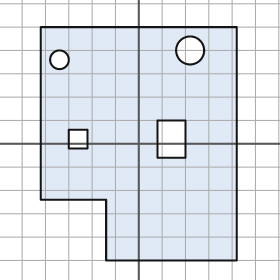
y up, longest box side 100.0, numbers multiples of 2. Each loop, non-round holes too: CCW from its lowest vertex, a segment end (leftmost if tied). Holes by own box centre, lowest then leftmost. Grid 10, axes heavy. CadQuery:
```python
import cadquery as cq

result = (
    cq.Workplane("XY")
    .moveTo(-14.0, -50.0)
    .lineTo(42.0, -50.0)
    .lineTo(42.0, 50.0)
    .lineTo(-42.0, 50.0)
    .lineTo(-42.0, -24.0)
    .lineTo(-14.0, -24.0)
    .close()
    .moveTo(-30.0, -2.0)
    .lineTo(-22.0, -2.0)
    .lineTo(-22.0, 6.0)
    .lineTo(-30.0, 6.0)
    .close()
    .moveTo(8.0, -6.0)
    .lineTo(20.0, -6.0)
    .lineTo(20.0, 10.0)
    .lineTo(8.0, 10.0)
    .close()
    .moveTo(-34.0, 36.0)
    .circle(4.0)
    .moveTo(22.0, 40.0)
    .circle(6.0)
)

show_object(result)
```